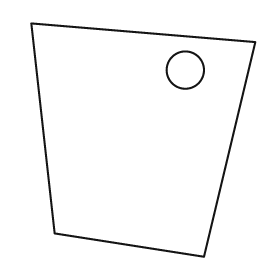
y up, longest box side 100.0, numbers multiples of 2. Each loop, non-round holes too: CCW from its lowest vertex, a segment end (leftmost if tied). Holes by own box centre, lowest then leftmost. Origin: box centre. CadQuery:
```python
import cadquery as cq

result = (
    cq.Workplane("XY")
    .moveTo(26.0, -50.0)
    .lineTo(48.0, 42.0)
    .lineTo(-48.0, 50.0)
    .lineTo(-38.0, -40.0)
    .close()
    .moveTo(18.0, 30.0)
    .circle(8.0)
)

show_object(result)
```